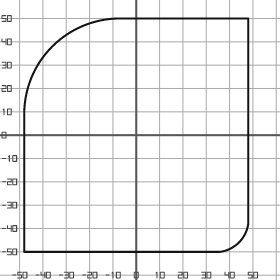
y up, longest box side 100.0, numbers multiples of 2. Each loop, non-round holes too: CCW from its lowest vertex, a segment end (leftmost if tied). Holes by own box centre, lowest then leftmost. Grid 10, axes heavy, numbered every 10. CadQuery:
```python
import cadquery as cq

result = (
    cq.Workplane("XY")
    .moveTo(-48.0, -50.0)
    .lineTo(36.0, -50.0)
    .threePointArc((44.0, -46.0), (48.0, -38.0))
    .lineTo(48.0, 50.0)
    .lineTo(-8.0, 50.0)
    .threePointArc((-36.0, 38.0), (-48.0, 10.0))
    .close()
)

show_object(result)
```